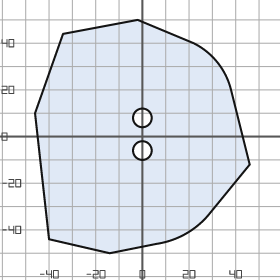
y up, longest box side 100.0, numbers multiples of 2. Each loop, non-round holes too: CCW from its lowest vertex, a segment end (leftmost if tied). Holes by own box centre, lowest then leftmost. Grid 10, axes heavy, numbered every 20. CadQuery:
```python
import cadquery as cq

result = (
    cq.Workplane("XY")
    .moveTo(-14.0, -50.0)
    .lineTo(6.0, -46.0)
    .threePointArc((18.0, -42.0), (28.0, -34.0))
    .lineTo(46.0, -12.0)
    .lineTo(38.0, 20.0)
    .threePointArc((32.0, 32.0), (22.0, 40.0))
    .lineTo(-2.0, 50.0)
    .lineTo(-34.0, 44.0)
    .lineTo(-46.0, 10.0)
    .lineTo(-40.0, -44.0)
    .close()
    .moveTo(0.0, -6.0)
    .circle(4.0)
    .moveTo(0.0, 8.0)
    .circle(4.0)
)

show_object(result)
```